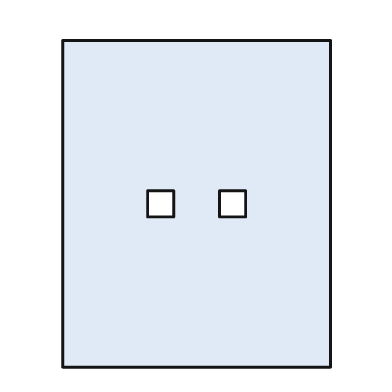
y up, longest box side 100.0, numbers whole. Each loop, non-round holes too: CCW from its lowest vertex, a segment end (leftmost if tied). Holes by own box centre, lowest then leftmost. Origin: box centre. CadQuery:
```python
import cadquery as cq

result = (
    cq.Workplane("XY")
    .moveTo(-41.0, -50.0)
    .lineTo(41.0, -50.0)
    .lineTo(41.0, 50.0)
    .lineTo(-41.0, 50.0)
    .close()
    .moveTo(-15.0, -4.0)
    .lineTo(-7.0, -4.0)
    .lineTo(-7.0, 4.0)
    .lineTo(-15.0, 4.0)
    .close()
    .moveTo(7.0, -4.0)
    .lineTo(15.0, -4.0)
    .lineTo(15.0, 4.0)
    .lineTo(7.0, 4.0)
    .close()
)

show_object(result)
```